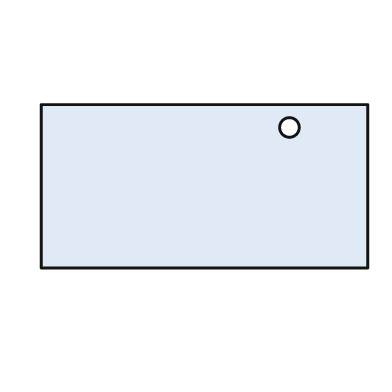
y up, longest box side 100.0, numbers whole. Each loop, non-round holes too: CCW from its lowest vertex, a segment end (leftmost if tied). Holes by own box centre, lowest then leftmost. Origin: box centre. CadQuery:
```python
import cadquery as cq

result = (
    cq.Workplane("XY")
    .moveTo(-50.0, -25.0)
    .lineTo(50.0, -25.0)
    .lineTo(50.0, 25.0)
    .lineTo(-50.0, 25.0)
    .close()
    .moveTo(26.0, 18.0)
    .circle(3.0)
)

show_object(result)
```